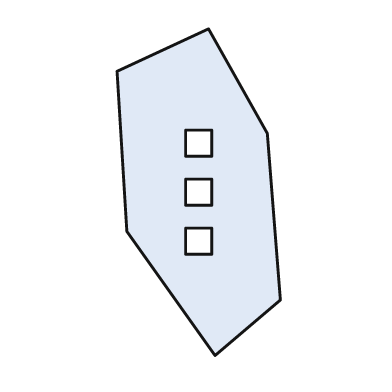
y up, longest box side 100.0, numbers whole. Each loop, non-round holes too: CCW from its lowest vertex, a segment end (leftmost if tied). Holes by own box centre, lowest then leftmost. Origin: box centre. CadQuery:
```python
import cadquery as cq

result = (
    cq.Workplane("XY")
    .moveTo(5.0, -50.0)
    .lineTo(25.0, -33.0)
    .lineTo(21.0, 18.0)
    .lineTo(3.0, 50.0)
    .lineTo(-25.0, 37.0)
    .lineTo(-22.0, -12.0)
    .close()
    .moveTo(-4.0, -19.0)
    .lineTo(4.0, -19.0)
    .lineTo(4.0, -11.0)
    .lineTo(-4.0, -11.0)
    .close()
    .moveTo(-4.0, -4.0)
    .lineTo(4.0, -4.0)
    .lineTo(4.0, 4.0)
    .lineTo(-4.0, 4.0)
    .close()
    .moveTo(-4.0, 11.0)
    .lineTo(4.0, 11.0)
    .lineTo(4.0, 19.0)
    .lineTo(-4.0, 19.0)
    .close()
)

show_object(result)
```